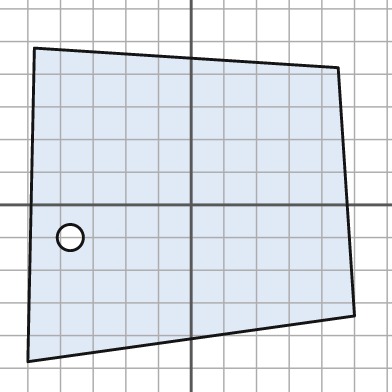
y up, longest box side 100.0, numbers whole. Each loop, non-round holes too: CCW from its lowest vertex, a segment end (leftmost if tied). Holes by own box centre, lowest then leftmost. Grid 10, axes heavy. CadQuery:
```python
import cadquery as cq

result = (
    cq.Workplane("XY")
    .moveTo(-50.0, -48.0)
    .lineTo(50.0, -34.0)
    .lineTo(45.0, 42.0)
    .lineTo(-48.0, 48.0)
    .close()
    .moveTo(-37.0, -10.0)
    .circle(4.0)
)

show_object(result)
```